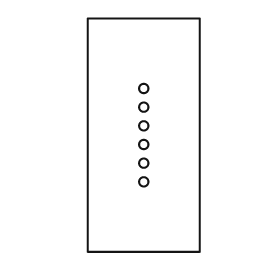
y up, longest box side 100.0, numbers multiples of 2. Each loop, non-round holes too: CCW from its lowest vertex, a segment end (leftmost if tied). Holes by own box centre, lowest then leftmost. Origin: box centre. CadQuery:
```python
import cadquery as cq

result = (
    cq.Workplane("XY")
    .moveTo(-24.0, -50.0)
    .lineTo(24.0, -50.0)
    .lineTo(24.0, 50.0)
    .lineTo(-24.0, 50.0)
    .close()
    .moveTo(0.0, -20.0)
    .circle(2.0)
    .moveTo(0.0, -12.0)
    .circle(2.0)
    .moveTo(0.0, -4.0)
    .circle(2.0)
    .moveTo(0.0, 4.0)
    .circle(2.0)
    .moveTo(0.0, 12.0)
    .circle(2.0)
    .moveTo(0.0, 20.0)
    .circle(2.0)
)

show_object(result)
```